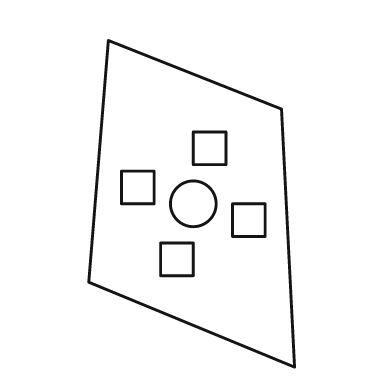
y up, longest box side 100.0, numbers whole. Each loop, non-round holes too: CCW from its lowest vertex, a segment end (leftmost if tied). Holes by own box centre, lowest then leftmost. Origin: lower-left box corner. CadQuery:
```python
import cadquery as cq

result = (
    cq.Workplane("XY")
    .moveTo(63.0, 0.0)
    .lineTo(59.0, 79.0)
    .lineTo(6.0, 100.0)
    .lineTo(0.0, 26.0)
    .close()
    .moveTo(22.0, 28.0)
    .lineTo(32.0, 28.0)
    .lineTo(32.0, 38.0)
    .lineTo(22.0, 38.0)
    .close()
    .moveTo(44.0, 40.0)
    .lineTo(54.0, 40.0)
    .lineTo(54.0, 50.0)
    .lineTo(44.0, 50.0)
    .close()
    .moveTo(32.0, 50.0)
    .circle(7.0)
    .moveTo(10.0, 50.0)
    .lineTo(20.0, 50.0)
    .lineTo(20.0, 60.0)
    .lineTo(10.0, 60.0)
    .close()
    .moveTo(32.0, 62.0)
    .lineTo(42.0, 62.0)
    .lineTo(42.0, 72.0)
    .lineTo(32.0, 72.0)
    .close()
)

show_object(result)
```